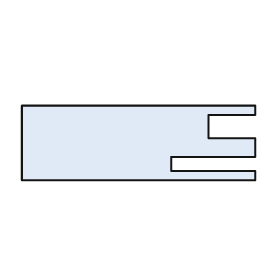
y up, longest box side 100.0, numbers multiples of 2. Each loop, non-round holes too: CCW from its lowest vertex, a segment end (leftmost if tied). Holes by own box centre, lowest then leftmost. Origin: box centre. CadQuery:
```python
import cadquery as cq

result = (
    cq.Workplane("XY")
    .moveTo(-50.0, -16.0)
    .lineTo(50.0, -16.0)
    .lineTo(50.0, -12.0)
    .lineTo(14.0, -12.0)
    .lineTo(14.0, -6.0)
    .lineTo(50.0, -6.0)
    .lineTo(50.0, 2.0)
    .lineTo(30.0, 2.0)
    .lineTo(30.0, 12.0)
    .lineTo(50.0, 12.0)
    .lineTo(50.0, 16.0)
    .lineTo(-50.0, 16.0)
    .close()
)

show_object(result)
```